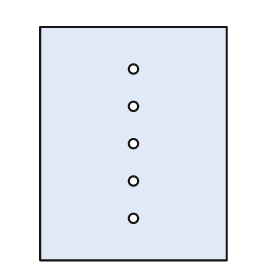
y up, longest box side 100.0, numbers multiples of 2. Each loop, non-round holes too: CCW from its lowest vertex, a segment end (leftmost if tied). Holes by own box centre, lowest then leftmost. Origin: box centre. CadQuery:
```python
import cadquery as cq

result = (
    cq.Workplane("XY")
    .moveTo(-40.0, -50.0)
    .lineTo(40.0, -50.0)
    .lineTo(40.0, 50.0)
    .lineTo(-40.0, 50.0)
    .close()
    .moveTo(0.0, -32.0)
    .circle(2.0)
    .moveTo(0.0, -16.0)
    .circle(2.0)
    .moveTo(0.0, 0.0)
    .circle(2.0)
    .moveTo(0.0, 16.0)
    .circle(2.0)
    .moveTo(0.0, 32.0)
    .circle(2.0)
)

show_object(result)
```